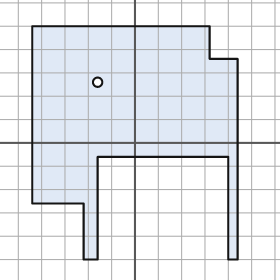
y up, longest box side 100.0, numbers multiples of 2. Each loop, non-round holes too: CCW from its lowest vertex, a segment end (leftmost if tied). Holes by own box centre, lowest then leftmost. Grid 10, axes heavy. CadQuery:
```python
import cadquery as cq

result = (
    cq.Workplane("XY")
    .moveTo(-22.0, -50.0)
    .lineTo(-16.0, -50.0)
    .lineTo(-16.0, -6.0)
    .lineTo(40.0, -6.0)
    .lineTo(40.0, -50.0)
    .lineTo(44.0, -50.0)
    .lineTo(44.0, 36.0)
    .lineTo(32.0, 36.0)
    .lineTo(32.0, 50.0)
    .lineTo(-44.0, 50.0)
    .lineTo(-44.0, -26.0)
    .lineTo(-22.0, -26.0)
    .close()
    .moveTo(-16.0, 26.0)
    .circle(2.0)
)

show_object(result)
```